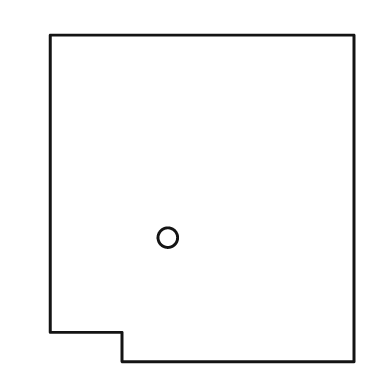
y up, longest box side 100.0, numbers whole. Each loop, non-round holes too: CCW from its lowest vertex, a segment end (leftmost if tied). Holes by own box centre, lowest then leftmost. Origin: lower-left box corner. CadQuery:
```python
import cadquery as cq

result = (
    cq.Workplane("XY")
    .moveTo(22.0, 0.0)
    .lineTo(93.0, 0.0)
    .lineTo(93.0, 100.0)
    .lineTo(0.0, 100.0)
    .lineTo(0.0, 9.0)
    .lineTo(22.0, 9.0)
    .close()
    .moveTo(36.0, 38.0)
    .circle(3.0)
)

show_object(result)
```